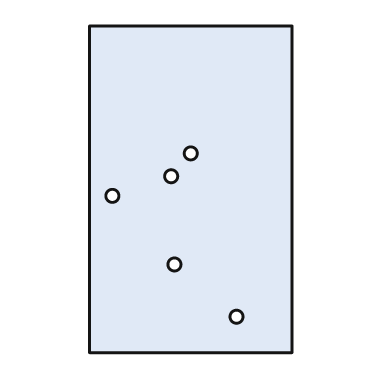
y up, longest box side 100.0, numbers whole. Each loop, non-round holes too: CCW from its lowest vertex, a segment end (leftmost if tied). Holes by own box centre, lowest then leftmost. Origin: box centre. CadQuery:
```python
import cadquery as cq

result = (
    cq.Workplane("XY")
    .moveTo(-31.0, -50.0)
    .lineTo(31.0, -50.0)
    .lineTo(31.0, 50.0)
    .lineTo(-31.0, 50.0)
    .close()
    .moveTo(14.0, -39.0)
    .circle(2.0)
    .moveTo(-5.0, -23.0)
    .circle(2.0)
    .moveTo(-24.0, -2.0)
    .circle(2.0)
    .moveTo(-6.0, 4.0)
    .circle(2.0)
    .moveTo(0.0, 11.0)
    .circle(2.0)
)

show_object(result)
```